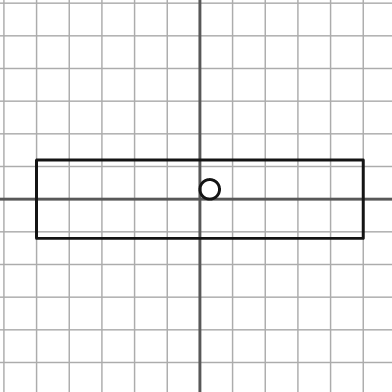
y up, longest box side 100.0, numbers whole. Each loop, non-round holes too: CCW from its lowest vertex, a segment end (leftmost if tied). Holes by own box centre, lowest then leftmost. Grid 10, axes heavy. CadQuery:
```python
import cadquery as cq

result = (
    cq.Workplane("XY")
    .moveTo(-50.0, -12.0)
    .lineTo(50.0, -12.0)
    .lineTo(50.0, 12.0)
    .lineTo(-50.0, 12.0)
    .close()
    .moveTo(3.0, 3.0)
    .circle(3.0)
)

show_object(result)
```